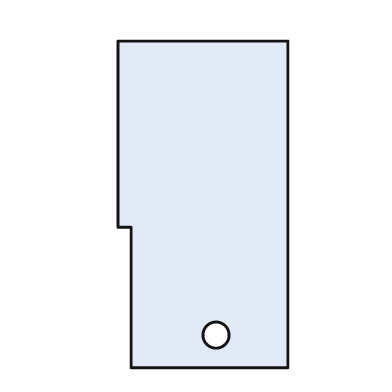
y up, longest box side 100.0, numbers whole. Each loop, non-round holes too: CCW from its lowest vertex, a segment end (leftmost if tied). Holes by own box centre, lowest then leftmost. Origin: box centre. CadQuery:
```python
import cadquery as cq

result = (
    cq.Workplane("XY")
    .moveTo(-22.0, -50.0)
    .lineTo(26.0, -50.0)
    .lineTo(26.0, 50.0)
    .lineTo(-26.0, 50.0)
    .lineTo(-26.0, -7.0)
    .lineTo(-22.0, -7.0)
    .close()
    .moveTo(4.0, -40.0)
    .circle(4.0)
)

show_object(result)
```